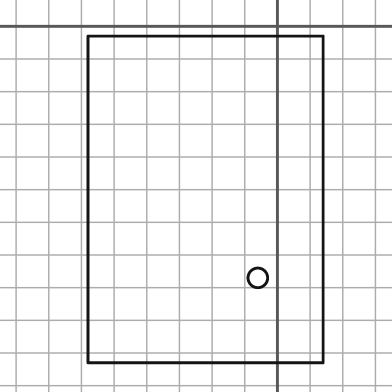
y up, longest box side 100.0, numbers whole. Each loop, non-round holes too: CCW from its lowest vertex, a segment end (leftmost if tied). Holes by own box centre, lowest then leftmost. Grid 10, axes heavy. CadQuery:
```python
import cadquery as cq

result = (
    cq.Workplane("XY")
    .moveTo(-58.0, -103.0)
    .lineTo(14.0, -103.0)
    .lineTo(14.0, -3.0)
    .lineTo(-58.0, -3.0)
    .close()
    .moveTo(-6.0, -77.0)
    .circle(3.0)
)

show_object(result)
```